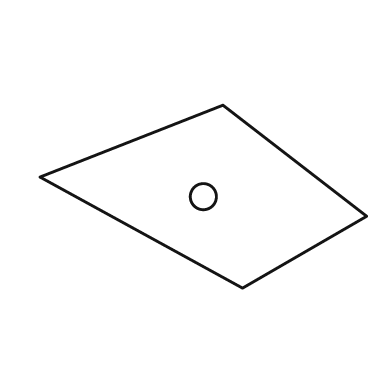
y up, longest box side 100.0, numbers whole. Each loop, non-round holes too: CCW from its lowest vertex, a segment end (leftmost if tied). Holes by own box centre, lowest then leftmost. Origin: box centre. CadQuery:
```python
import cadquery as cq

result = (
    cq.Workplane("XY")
    .moveTo(12.0, -28.0)
    .lineTo(50.0, -6.0)
    .lineTo(6.0, 28.0)
    .lineTo(-50.0, 6.0)
    .close()
    .moveTo(0.0, 0.0)
    .circle(4.0)
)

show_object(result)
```